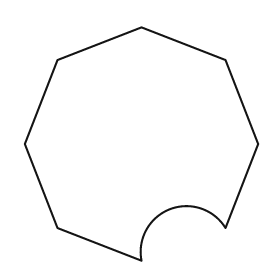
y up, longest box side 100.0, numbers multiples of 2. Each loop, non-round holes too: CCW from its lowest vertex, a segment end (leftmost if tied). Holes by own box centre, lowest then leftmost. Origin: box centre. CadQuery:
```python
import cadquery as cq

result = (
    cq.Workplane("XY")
    .moveTo(0.0, -50.0)
    .threePointArc((12.0, -28.0), (36.0, -36.0))
    .lineTo(50.0, 0.0)
    .lineTo(36.0, 36.0)
    .lineTo(0.0, 50.0)
    .lineTo(-36.0, 36.0)
    .lineTo(-50.0, 0.0)
    .lineTo(-36.0, -36.0)
    .close()
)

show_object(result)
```